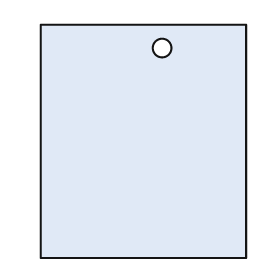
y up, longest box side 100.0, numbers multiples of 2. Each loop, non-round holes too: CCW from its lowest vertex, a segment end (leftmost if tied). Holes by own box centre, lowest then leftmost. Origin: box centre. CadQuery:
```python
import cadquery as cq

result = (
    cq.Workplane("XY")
    .moveTo(-44.0, -50.0)
    .lineTo(44.0, -50.0)
    .lineTo(44.0, 50.0)
    .lineTo(-44.0, 50.0)
    .close()
    .moveTo(8.0, 40.0)
    .circle(4.0)
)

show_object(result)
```